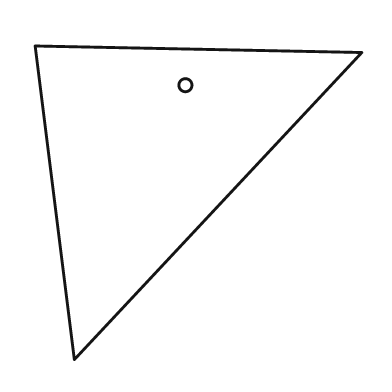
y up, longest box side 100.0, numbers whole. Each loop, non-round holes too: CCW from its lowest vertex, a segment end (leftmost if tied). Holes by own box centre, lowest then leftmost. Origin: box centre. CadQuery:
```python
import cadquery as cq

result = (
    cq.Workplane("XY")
    .moveTo(-38.0, -48.0)
    .lineTo(50.0, 46.0)
    .lineTo(-50.0, 48.0)
    .close()
    .moveTo(-4.0, 36.0)
    .circle(2.0)
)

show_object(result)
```